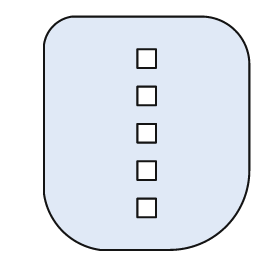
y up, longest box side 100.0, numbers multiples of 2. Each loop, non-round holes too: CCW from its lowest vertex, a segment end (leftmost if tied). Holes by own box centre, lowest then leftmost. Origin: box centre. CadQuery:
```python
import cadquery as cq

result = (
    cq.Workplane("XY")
    .moveTo(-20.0, -50.0)
    .lineTo(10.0, -50.0)
    .threePointArc((34.0, -40.0), (44.0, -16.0))
    .lineTo(44.0, 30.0)
    .threePointArc((38.0, 44.0), (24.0, 50.0))
    .lineTo(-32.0, 50.0)
    .threePointArc((-40.0, 46.0), (-44.0, 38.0))
    .lineTo(-44.0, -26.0)
    .threePointArc((-36.0, -42.0), (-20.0, -50.0))
    .close()
    .moveTo(-4.0, -36.0)
    .lineTo(4.0, -36.0)
    .lineTo(4.0, -28.0)
    .lineTo(-4.0, -28.0)
    .close()
    .moveTo(-4.0, -20.0)
    .lineTo(4.0, -20.0)
    .lineTo(4.0, -12.0)
    .lineTo(-4.0, -12.0)
    .close()
    .moveTo(-4.0, -4.0)
    .lineTo(4.0, -4.0)
    .lineTo(4.0, 4.0)
    .lineTo(-4.0, 4.0)
    .close()
    .moveTo(-4.0, 12.0)
    .lineTo(4.0, 12.0)
    .lineTo(4.0, 20.0)
    .lineTo(-4.0, 20.0)
    .close()
    .moveTo(-4.0, 28.0)
    .lineTo(4.0, 28.0)
    .lineTo(4.0, 36.0)
    .lineTo(-4.0, 36.0)
    .close()
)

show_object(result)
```